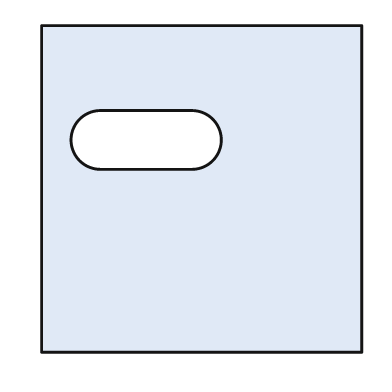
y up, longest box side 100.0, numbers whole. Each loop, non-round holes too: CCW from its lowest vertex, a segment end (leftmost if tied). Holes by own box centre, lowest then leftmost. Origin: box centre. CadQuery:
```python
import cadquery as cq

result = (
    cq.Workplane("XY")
    .moveTo(-49.0, -50.0)
    .lineTo(49.0, -50.0)
    .lineTo(49.0, 50.0)
    .lineTo(-49.0, 50.0)
    .close()
    .moveTo(-31.0, 6.0)
    .lineTo(-3.0, 6.0)
    .threePointArc((6.0, 15.0), (-3.0, 24.0))
    .lineTo(-31.0, 24.0)
    .threePointArc((-40.0, 15.0), (-31.0, 6.0))
    .close()
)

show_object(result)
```